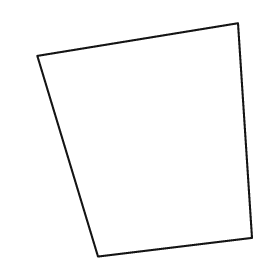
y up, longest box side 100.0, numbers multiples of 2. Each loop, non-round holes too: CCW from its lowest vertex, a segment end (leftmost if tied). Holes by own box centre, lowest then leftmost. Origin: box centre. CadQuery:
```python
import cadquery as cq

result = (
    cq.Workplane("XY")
    .moveTo(-20.0, -50.0)
    .lineTo(46.0, -42.0)
    .lineTo(40.0, 50.0)
    .lineTo(-46.0, 36.0)
    .close()
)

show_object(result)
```